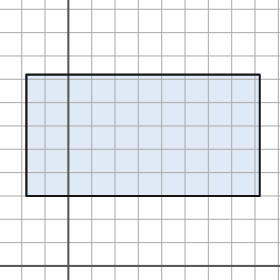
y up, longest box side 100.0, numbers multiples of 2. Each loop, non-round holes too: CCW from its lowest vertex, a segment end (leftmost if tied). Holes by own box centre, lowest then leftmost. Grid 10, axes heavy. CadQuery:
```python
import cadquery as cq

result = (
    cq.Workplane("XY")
    .moveTo(-18.0, 30.0)
    .lineTo(82.0, 30.0)
    .lineTo(82.0, 82.0)
    .lineTo(-18.0, 82.0)
    .close()
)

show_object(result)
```